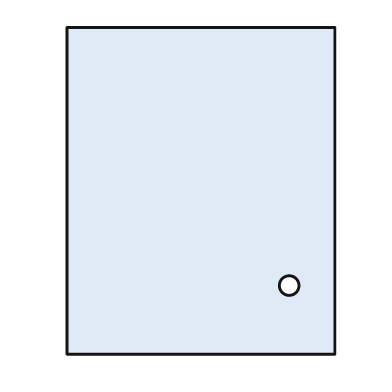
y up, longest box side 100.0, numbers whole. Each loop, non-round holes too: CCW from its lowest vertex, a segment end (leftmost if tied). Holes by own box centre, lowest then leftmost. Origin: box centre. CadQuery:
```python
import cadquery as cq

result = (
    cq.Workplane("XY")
    .moveTo(-41.0, -50.0)
    .lineTo(41.0, -50.0)
    .lineTo(41.0, 50.0)
    .lineTo(-41.0, 50.0)
    .close()
    .moveTo(27.0, -29.0)
    .circle(3.0)
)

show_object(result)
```